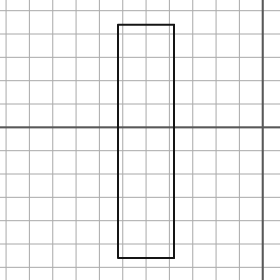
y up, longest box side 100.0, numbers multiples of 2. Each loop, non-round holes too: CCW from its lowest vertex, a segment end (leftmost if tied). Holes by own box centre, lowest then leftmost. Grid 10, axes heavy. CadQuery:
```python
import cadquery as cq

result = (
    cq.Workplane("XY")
    .moveTo(-62.0, -56.0)
    .lineTo(-38.0, -56.0)
    .lineTo(-38.0, 44.0)
    .lineTo(-62.0, 44.0)
    .close()
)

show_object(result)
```